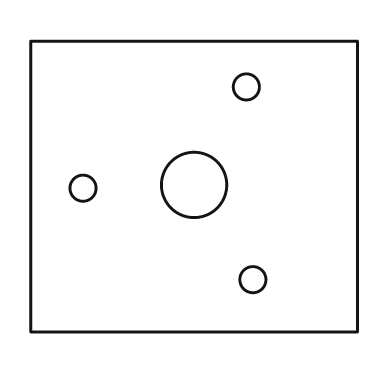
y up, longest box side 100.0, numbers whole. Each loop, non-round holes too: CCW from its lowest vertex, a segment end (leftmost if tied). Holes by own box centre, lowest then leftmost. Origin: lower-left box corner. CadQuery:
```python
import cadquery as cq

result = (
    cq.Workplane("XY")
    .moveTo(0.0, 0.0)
    .lineTo(100.0, 0.0)
    .lineTo(100.0, 89.0)
    .lineTo(0.0, 89.0)
    .close()
    .moveTo(68.0, 16.0)
    .circle(4.0)
    .moveTo(16.0, 44.0)
    .circle(4.0)
    .moveTo(50.0, 45.0)
    .circle(10.0)
    .moveTo(66.0, 75.0)
    .circle(4.0)
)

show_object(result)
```